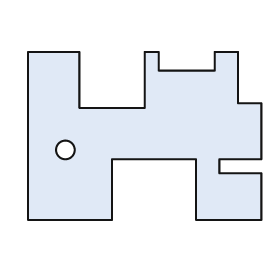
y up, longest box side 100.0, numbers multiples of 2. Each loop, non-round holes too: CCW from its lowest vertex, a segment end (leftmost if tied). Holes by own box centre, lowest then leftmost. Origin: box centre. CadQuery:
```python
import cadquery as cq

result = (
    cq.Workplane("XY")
    .moveTo(-50.0, -36.0)
    .lineTo(-14.0, -36.0)
    .lineTo(-14.0, -10.0)
    .lineTo(22.0, -10.0)
    .lineTo(22.0, -36.0)
    .lineTo(50.0, -36.0)
    .lineTo(50.0, -16.0)
    .lineTo(32.0, -16.0)
    .lineTo(32.0, -10.0)
    .lineTo(50.0, -10.0)
    .lineTo(50.0, 14.0)
    .lineTo(40.0, 14.0)
    .lineTo(40.0, 36.0)
    .lineTo(30.0, 36.0)
    .lineTo(30.0, 28.0)
    .lineTo(6.0, 28.0)
    .lineTo(6.0, 36.0)
    .lineTo(0.0, 36.0)
    .lineTo(0.0, 12.0)
    .lineTo(-28.0, 12.0)
    .lineTo(-28.0, 36.0)
    .lineTo(-50.0, 36.0)
    .close()
    .moveTo(-34.0, -6.0)
    .circle(4.0)
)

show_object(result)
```